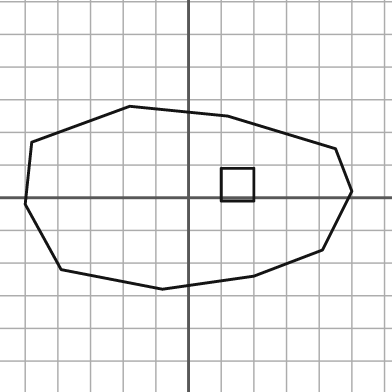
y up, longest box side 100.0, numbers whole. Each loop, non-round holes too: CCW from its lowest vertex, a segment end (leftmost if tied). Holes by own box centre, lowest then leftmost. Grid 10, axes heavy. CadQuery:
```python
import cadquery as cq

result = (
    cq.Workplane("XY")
    .moveTo(-8.0, -28.0)
    .lineTo(20.0, -24.0)
    .lineTo(41.0, -16.0)
    .lineTo(50.0, 2.0)
    .lineTo(45.0, 15.0)
    .lineTo(12.0, 25.0)
    .lineTo(-18.0, 28.0)
    .lineTo(-48.0, 17.0)
    .lineTo(-50.0, -2.0)
    .lineTo(-39.0, -22.0)
    .close()
    .moveTo(10.0, -1.0)
    .lineTo(20.0, -1.0)
    .lineTo(20.0, 9.0)
    .lineTo(10.0, 9.0)
    .close()
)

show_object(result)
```